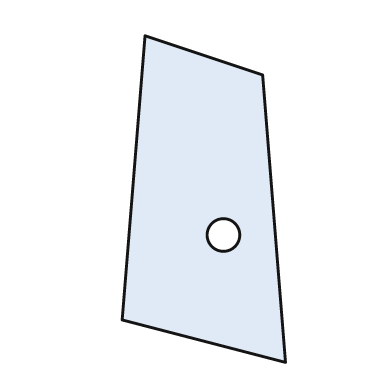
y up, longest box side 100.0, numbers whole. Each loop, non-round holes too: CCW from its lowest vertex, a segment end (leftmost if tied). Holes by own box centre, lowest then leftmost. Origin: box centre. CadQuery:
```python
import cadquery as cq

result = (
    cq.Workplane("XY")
    .moveTo(25.0, -50.0)
    .lineTo(18.0, 38.0)
    .lineTo(-18.0, 50.0)
    .lineTo(-25.0, -37.0)
    .close()
    .moveTo(6.0, -11.0)
    .circle(5.0)
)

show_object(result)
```